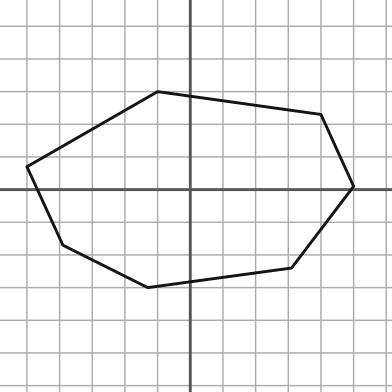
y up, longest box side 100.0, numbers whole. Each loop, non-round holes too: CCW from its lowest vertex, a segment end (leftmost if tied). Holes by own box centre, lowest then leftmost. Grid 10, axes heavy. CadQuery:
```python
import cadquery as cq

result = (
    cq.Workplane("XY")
    .moveTo(-13.0, -30.0)
    .lineTo(31.0, -24.0)
    .lineTo(50.0, 1.0)
    .lineTo(40.0, 23.0)
    .lineTo(-10.0, 30.0)
    .lineTo(-50.0, 7.0)
    .lineTo(-39.0, -17.0)
    .close()
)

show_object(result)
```